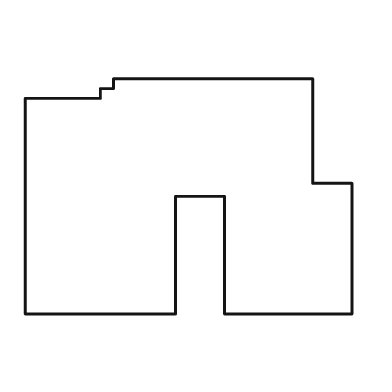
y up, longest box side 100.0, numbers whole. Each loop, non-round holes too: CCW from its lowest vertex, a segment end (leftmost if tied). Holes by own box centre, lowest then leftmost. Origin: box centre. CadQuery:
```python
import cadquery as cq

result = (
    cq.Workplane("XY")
    .moveTo(-50.0, -36.0)
    .lineTo(-4.0, -36.0)
    .lineTo(-4.0, 0.0)
    .lineTo(11.0, 0.0)
    .lineTo(11.0, -36.0)
    .lineTo(50.0, -36.0)
    .lineTo(50.0, 4.0)
    .lineTo(38.0, 4.0)
    .lineTo(38.0, 36.0)
    .lineTo(-23.0, 36.0)
    .lineTo(-23.0, 33.0)
    .lineTo(-27.0, 33.0)
    .lineTo(-27.0, 30.0)
    .lineTo(-50.0, 30.0)
    .close()
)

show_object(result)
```